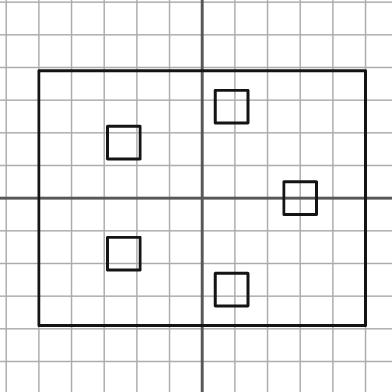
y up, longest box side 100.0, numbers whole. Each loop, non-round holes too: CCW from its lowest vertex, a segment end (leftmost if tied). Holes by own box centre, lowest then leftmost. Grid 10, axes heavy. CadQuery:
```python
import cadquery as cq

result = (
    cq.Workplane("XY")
    .moveTo(-50.0, -39.0)
    .lineTo(50.0, -39.0)
    .lineTo(50.0, 39.0)
    .lineTo(-50.0, 39.0)
    .close()
    .moveTo(4.0, -33.0)
    .lineTo(14.0, -33.0)
    .lineTo(14.0, -23.0)
    .lineTo(4.0, -23.0)
    .close()
    .moveTo(-29.0, -22.0)
    .lineTo(-19.0, -22.0)
    .lineTo(-19.0, -12.0)
    .lineTo(-29.0, -12.0)
    .close()
    .moveTo(25.0, -5.0)
    .lineTo(35.0, -5.0)
    .lineTo(35.0, 5.0)
    .lineTo(25.0, 5.0)
    .close()
    .moveTo(-29.0, 12.0)
    .lineTo(-19.0, 12.0)
    .lineTo(-19.0, 22.0)
    .lineTo(-29.0, 22.0)
    .close()
    .moveTo(4.0, 23.0)
    .lineTo(14.0, 23.0)
    .lineTo(14.0, 33.0)
    .lineTo(4.0, 33.0)
    .close()
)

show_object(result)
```